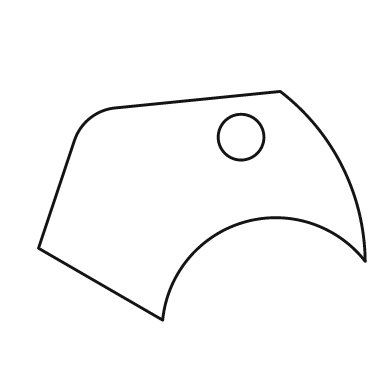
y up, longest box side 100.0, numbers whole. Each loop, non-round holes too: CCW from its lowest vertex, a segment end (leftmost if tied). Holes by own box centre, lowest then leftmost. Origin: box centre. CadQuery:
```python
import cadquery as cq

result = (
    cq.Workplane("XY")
    .moveTo(-12.0, -35.0)
    .threePointArc((13.0, -5.0), (50.0, -17.0))
    .threePointArc((43.0, 12.0), (24.0, 35.0))
    .lineTo(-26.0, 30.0)
    .threePointArc((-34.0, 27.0), (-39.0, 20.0))
    .lineTo(-50.0, -13.0)
    .close()
    .moveTo(12.0, 21.0)
    .circle(7.0)
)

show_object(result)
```